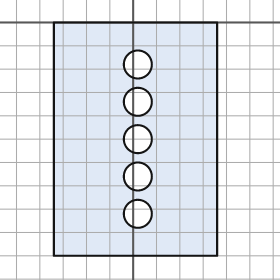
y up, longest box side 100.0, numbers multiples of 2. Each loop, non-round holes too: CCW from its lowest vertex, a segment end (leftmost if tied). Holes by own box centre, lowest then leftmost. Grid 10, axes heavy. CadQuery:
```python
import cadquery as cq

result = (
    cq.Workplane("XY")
    .moveTo(-34.0, -100.0)
    .lineTo(36.0, -100.0)
    .lineTo(36.0, 0.0)
    .lineTo(-34.0, 0.0)
    .close()
    .moveTo(2.0, -82.0)
    .circle(6.0)
    .moveTo(2.0, -66.0)
    .circle(6.0)
    .moveTo(2.0, -50.0)
    .circle(6.0)
    .moveTo(2.0, -34.0)
    .circle(6.0)
    .moveTo(2.0, -18.0)
    .circle(6.0)
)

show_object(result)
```